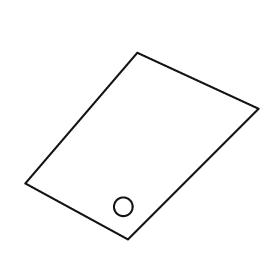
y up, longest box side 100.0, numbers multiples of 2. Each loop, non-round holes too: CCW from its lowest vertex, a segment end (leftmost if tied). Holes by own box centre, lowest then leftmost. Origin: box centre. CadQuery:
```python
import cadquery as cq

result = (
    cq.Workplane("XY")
    .moveTo(-6.0, -40.0)
    .lineTo(50.0, 16.0)
    .lineTo(-2.0, 40.0)
    .lineTo(-50.0, -16.0)
    .close()
    .moveTo(-8.0, -26.0)
    .circle(4.0)
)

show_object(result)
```